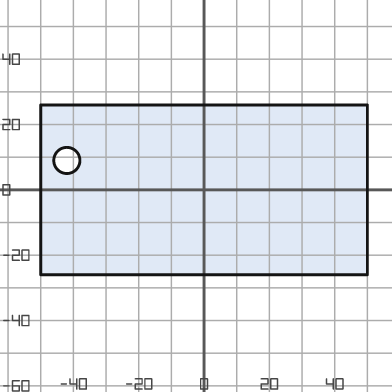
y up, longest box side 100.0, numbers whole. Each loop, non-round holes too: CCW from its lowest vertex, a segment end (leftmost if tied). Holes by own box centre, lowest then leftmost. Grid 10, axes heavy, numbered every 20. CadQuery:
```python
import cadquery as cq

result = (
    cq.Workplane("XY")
    .moveTo(-50.0, -26.0)
    .lineTo(50.0, -26.0)
    .lineTo(50.0, 26.0)
    .lineTo(-50.0, 26.0)
    .close()
    .moveTo(-42.0, 9.0)
    .circle(4.0)
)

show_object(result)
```